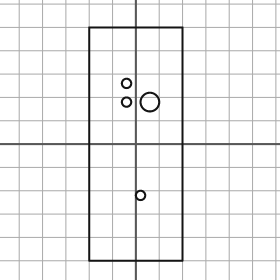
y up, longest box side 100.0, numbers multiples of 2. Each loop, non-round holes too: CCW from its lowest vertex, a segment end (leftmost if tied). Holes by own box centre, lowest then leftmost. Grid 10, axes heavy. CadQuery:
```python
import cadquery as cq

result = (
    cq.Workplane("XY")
    .moveTo(-20.0, -50.0)
    .lineTo(20.0, -50.0)
    .lineTo(20.0, 50.0)
    .lineTo(-20.0, 50.0)
    .close()
    .moveTo(2.0, -22.0)
    .circle(2.0)
    .moveTo(-4.0, 18.0)
    .circle(2.0)
    .moveTo(6.0, 18.0)
    .circle(4.0)
    .moveTo(-4.0, 26.0)
    .circle(2.0)
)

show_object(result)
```